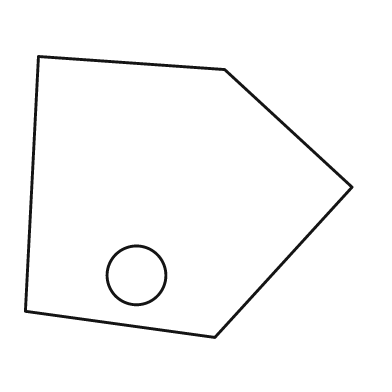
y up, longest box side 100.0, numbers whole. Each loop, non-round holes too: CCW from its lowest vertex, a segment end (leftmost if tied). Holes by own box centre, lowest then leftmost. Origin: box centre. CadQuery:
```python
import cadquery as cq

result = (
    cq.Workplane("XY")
    .moveTo(8.0, -43.0)
    .lineTo(50.0, 3.0)
    .lineTo(11.0, 39.0)
    .lineTo(-46.0, 43.0)
    .lineTo(-50.0, -35.0)
    .close()
    .moveTo(-16.0, -24.0)
    .circle(9.0)
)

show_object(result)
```